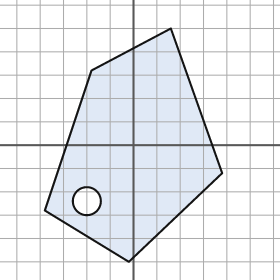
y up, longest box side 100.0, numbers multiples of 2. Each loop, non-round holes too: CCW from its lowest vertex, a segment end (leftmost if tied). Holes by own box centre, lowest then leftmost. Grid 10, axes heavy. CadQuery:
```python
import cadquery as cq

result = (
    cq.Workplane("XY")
    .moveTo(-2.0, -50.0)
    .lineTo(38.0, -12.0)
    .lineTo(16.0, 50.0)
    .lineTo(-18.0, 32.0)
    .lineTo(-38.0, -28.0)
    .close()
    .moveTo(-20.0, -24.0)
    .circle(6.0)
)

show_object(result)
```